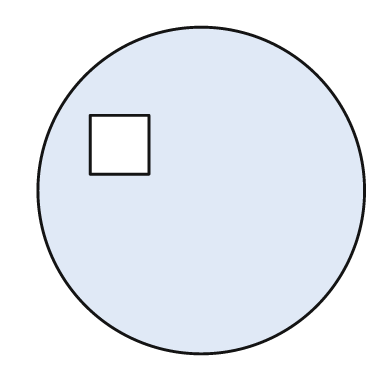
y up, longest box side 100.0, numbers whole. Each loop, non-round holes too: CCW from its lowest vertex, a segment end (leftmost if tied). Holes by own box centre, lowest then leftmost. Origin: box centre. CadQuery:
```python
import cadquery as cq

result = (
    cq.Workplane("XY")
    .moveTo(0.0, 0.0)
    .circle(50.0)
    .moveTo(-34.0, 5.0)
    .lineTo(-16.0, 5.0)
    .lineTo(-16.0, 23.0)
    .lineTo(-34.0, 23.0)
    .close()
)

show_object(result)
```